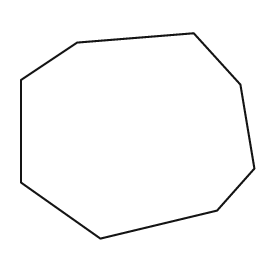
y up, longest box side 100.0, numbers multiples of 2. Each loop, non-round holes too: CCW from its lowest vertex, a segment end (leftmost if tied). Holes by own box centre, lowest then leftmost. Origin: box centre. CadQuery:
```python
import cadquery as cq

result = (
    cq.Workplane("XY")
    .moveTo(-16.0, -44.0)
    .lineTo(34.0, -32.0)
    .lineTo(50.0, -14.0)
    .lineTo(44.0, 22.0)
    .lineTo(24.0, 44.0)
    .lineTo(-26.0, 40.0)
    .lineTo(-50.0, 24.0)
    .lineTo(-50.0, -20.0)
    .close()
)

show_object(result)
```